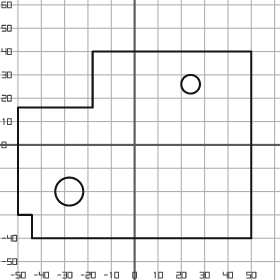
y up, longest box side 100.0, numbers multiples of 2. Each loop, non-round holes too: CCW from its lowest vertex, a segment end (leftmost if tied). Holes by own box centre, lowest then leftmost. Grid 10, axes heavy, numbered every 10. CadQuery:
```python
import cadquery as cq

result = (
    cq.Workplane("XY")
    .moveTo(-44.0, -40.0)
    .lineTo(50.0, -40.0)
    .lineTo(50.0, 40.0)
    .lineTo(-18.0, 40.0)
    .lineTo(-18.0, 16.0)
    .lineTo(-50.0, 16.0)
    .lineTo(-50.0, -30.0)
    .lineTo(-44.0, -30.0)
    .close()
    .moveTo(-28.0, -20.0)
    .circle(6.0)
    .moveTo(24.0, 26.0)
    .circle(4.0)
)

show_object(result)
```